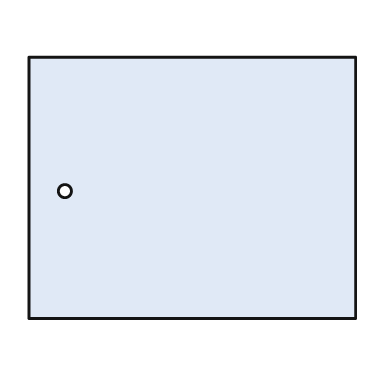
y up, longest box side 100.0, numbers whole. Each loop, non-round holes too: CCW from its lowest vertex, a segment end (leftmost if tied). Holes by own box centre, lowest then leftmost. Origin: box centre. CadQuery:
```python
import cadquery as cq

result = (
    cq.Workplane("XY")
    .moveTo(-50.0, -40.0)
    .lineTo(50.0, -40.0)
    .lineTo(50.0, 40.0)
    .lineTo(-50.0, 40.0)
    .close()
    .moveTo(-39.0, -1.0)
    .circle(2.0)
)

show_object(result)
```